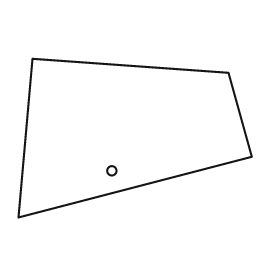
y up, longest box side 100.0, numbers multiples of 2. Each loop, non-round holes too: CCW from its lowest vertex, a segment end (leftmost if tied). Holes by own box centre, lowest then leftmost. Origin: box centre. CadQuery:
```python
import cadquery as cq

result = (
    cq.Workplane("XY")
    .moveTo(-50.0, -34.0)
    .lineTo(50.0, -8.0)
    .lineTo(40.0, 28.0)
    .lineTo(-44.0, 34.0)
    .close()
    .moveTo(-10.0, -14.0)
    .circle(2.0)
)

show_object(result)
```